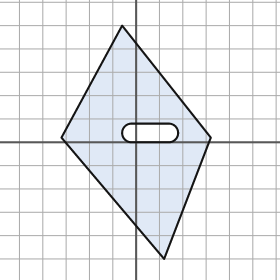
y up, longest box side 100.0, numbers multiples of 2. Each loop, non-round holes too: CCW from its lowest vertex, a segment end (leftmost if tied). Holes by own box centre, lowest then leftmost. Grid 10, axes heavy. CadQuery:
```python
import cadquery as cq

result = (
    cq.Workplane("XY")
    .moveTo(12.0, -50.0)
    .lineTo(32.0, 2.0)
    .lineTo(-6.0, 50.0)
    .lineTo(-32.0, 2.0)
    .close()
    .moveTo(-2.0, 0.0)
    .lineTo(14.0, 0.0)
    .threePointArc((18.0, 4.0), (14.0, 8.0))
    .lineTo(-2.0, 8.0)
    .threePointArc((-6.0, 4.0), (-2.0, 0.0))
    .close()
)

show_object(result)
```